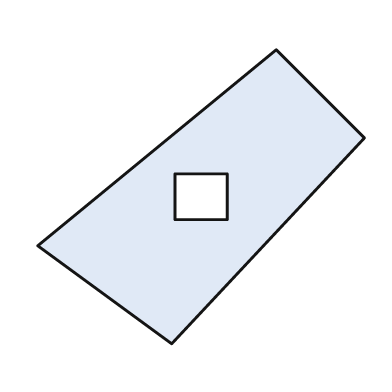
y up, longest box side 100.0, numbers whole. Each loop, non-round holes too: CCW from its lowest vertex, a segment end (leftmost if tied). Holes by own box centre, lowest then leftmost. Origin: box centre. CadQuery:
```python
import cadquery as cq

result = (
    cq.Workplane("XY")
    .moveTo(-9.0, -45.0)
    .lineTo(50.0, 18.0)
    .lineTo(23.0, 45.0)
    .lineTo(-50.0, -15.0)
    .close()
    .moveTo(-8.0, -7.0)
    .lineTo(8.0, -7.0)
    .lineTo(8.0, 7.0)
    .lineTo(-8.0, 7.0)
    .close()
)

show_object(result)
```